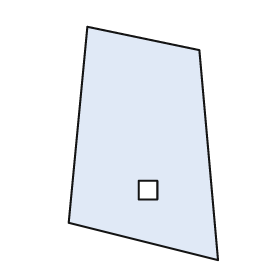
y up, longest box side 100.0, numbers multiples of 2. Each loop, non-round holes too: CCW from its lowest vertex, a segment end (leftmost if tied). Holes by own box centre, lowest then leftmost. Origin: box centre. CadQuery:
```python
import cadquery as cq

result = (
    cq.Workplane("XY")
    .moveTo(32.0, -50.0)
    .lineTo(24.0, 40.0)
    .lineTo(-24.0, 50.0)
    .lineTo(-32.0, -34.0)
    .close()
    .moveTo(-2.0, -24.0)
    .lineTo(6.0, -24.0)
    .lineTo(6.0, -16.0)
    .lineTo(-2.0, -16.0)
    .close()
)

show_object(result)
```